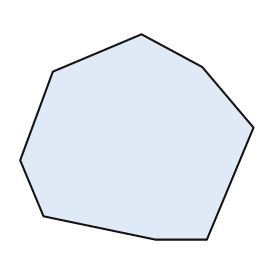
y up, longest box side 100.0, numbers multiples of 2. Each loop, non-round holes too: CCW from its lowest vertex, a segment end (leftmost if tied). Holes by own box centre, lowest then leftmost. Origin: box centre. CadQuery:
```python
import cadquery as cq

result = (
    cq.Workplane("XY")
    .moveTo(8.0, -44.0)
    .lineTo(30.0, -44.0)
    .lineTo(50.0, 4.0)
    .lineTo(28.0, 30.0)
    .lineTo(2.0, 44.0)
    .lineTo(-36.0, 28.0)
    .lineTo(-50.0, -10.0)
    .lineTo(-40.0, -34.0)
    .close()
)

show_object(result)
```